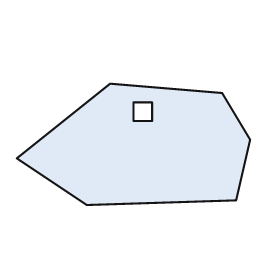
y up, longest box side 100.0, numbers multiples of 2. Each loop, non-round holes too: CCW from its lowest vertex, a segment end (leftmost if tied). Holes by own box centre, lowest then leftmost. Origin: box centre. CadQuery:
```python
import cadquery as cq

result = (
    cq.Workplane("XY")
    .moveTo(-20.0, -26.0)
    .lineTo(44.0, -24.0)
    .lineTo(50.0, 2.0)
    .lineTo(38.0, 22.0)
    .lineTo(-10.0, 26.0)
    .lineTo(-50.0, -6.0)
    .close()
    .moveTo(0.0, 10.0)
    .lineTo(8.0, 10.0)
    .lineTo(8.0, 18.0)
    .lineTo(0.0, 18.0)
    .close()
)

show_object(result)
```